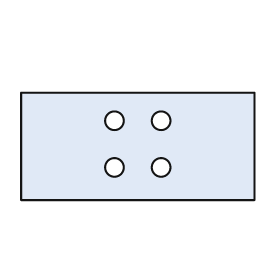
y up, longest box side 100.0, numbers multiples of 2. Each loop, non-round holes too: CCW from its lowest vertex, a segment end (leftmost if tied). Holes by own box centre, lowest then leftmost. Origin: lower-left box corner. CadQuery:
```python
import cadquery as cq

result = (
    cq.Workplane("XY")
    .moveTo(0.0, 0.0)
    .lineTo(100.0, 0.0)
    .lineTo(100.0, 46.0)
    .lineTo(0.0, 46.0)
    .close()
    .moveTo(40.0, 14.0)
    .circle(4.0)
    .moveTo(60.0, 14.0)
    .circle(4.0)
    .moveTo(40.0, 34.0)
    .circle(4.0)
    .moveTo(60.0, 34.0)
    .circle(4.0)
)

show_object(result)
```